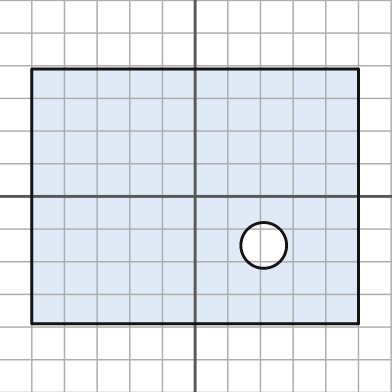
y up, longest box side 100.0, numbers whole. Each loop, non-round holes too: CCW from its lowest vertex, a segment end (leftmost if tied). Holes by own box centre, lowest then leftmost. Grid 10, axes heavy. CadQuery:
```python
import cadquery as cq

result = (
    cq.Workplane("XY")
    .moveTo(-50.0, -39.0)
    .lineTo(50.0, -39.0)
    .lineTo(50.0, 39.0)
    .lineTo(-50.0, 39.0)
    .close()
    .moveTo(21.0, -15.0)
    .circle(7.0)
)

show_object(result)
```